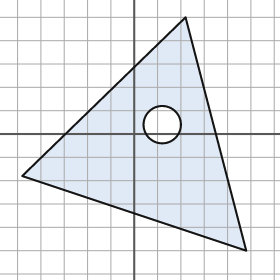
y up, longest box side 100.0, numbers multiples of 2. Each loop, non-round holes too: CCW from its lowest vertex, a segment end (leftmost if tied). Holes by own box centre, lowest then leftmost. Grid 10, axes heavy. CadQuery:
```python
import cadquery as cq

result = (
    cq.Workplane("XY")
    .moveTo(48.0, -50.0)
    .lineTo(22.0, 50.0)
    .lineTo(-48.0, -18.0)
    .close()
    .moveTo(12.0, 4.0)
    .circle(8.0)
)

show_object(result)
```